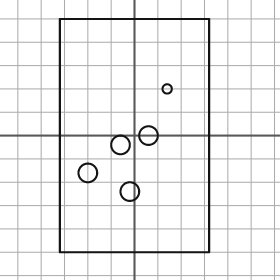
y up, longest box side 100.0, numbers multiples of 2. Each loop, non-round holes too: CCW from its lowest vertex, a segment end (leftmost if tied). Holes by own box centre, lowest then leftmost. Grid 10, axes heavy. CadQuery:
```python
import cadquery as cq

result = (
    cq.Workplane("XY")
    .moveTo(-32.0, -50.0)
    .lineTo(32.0, -50.0)
    .lineTo(32.0, 50.0)
    .lineTo(-32.0, 50.0)
    .close()
    .moveTo(-2.0, -24.0)
    .circle(4.0)
    .moveTo(-20.0, -16.0)
    .circle(4.0)
    .moveTo(-6.0, -4.0)
    .circle(4.0)
    .moveTo(6.0, 0.0)
    .circle(4.0)
    .moveTo(14.0, 20.0)
    .circle(2.0)
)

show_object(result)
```